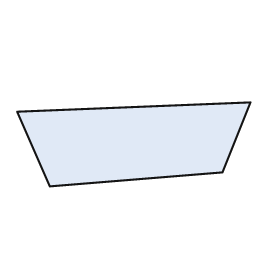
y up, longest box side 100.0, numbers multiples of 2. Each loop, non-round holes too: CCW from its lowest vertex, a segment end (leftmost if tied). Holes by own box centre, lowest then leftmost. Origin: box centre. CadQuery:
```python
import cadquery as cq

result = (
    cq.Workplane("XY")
    .moveTo(-36.0, -18.0)
    .lineTo(38.0, -12.0)
    .lineTo(50.0, 18.0)
    .lineTo(-50.0, 14.0)
    .close()
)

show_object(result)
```